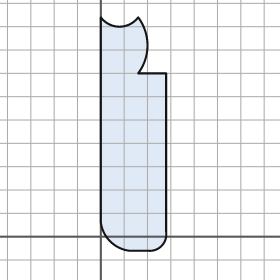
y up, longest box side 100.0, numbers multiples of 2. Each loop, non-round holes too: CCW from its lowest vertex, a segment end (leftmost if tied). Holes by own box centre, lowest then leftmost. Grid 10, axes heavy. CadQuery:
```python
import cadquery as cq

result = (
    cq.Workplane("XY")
    .moveTo(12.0, -6.0)
    .lineTo(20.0, -6.0)
    .threePointArc((26.0, -4.0), (28.0, 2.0))
    .lineTo(28.0, 70.0)
    .lineTo(16.0, 70.0)
    .threePointArc((20.0, 82.0), (16.0, 94.0))
    .threePointArc((8.0, 90.0), (0.0, 94.0))
    .lineTo(0.0, 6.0)
    .threePointArc((4.0, -2.0), (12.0, -6.0))
    .close()
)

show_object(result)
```